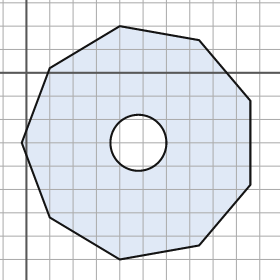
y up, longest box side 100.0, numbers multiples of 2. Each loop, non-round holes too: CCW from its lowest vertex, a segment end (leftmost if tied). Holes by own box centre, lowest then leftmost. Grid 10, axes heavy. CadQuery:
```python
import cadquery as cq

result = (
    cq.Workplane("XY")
    .moveTo(40.0, -80.0)
    .lineTo(74.0, -74.0)
    .lineTo(96.0, -48.0)
    .lineTo(96.0, -12.0)
    .lineTo(74.0, 14.0)
    .lineTo(40.0, 20.0)
    .lineTo(10.0, 2.0)
    .lineTo(-2.0, -30.0)
    .lineTo(10.0, -62.0)
    .close()
    .moveTo(48.0, -30.0)
    .circle(12.0)
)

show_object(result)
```